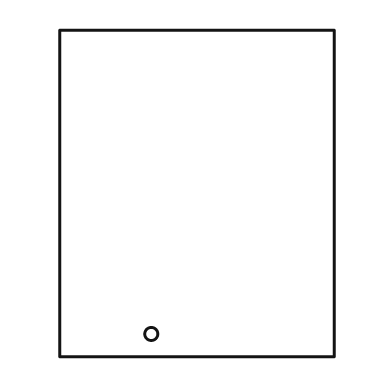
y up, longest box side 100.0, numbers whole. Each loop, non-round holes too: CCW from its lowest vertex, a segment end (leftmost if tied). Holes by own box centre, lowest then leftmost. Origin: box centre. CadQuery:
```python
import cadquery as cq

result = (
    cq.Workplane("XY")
    .moveTo(-42.0, -50.0)
    .lineTo(42.0, -50.0)
    .lineTo(42.0, 50.0)
    .lineTo(-42.0, 50.0)
    .close()
    .moveTo(-14.0, -43.0)
    .circle(2.0)
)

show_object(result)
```